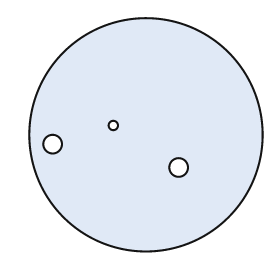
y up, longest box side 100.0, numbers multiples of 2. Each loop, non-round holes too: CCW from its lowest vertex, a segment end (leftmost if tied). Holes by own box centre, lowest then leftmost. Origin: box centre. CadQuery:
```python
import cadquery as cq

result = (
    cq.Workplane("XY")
    .moveTo(0.0, 0.0)
    .circle(50.0)
    .moveTo(14.0, -14.0)
    .circle(4.0)
    .moveTo(-40.0, -4.0)
    .circle(4.0)
    .moveTo(-14.0, 4.0)
    .circle(2.0)
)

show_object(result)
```